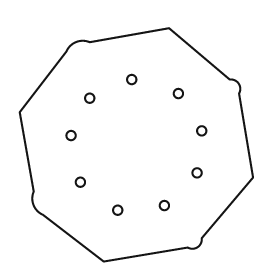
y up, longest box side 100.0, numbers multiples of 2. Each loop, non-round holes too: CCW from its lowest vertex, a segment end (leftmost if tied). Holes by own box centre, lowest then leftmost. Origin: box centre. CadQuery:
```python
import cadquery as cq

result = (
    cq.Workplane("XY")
    .moveTo(-14.0, -50.0)
    .lineTo(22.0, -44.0)
    .threePointArc((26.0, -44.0), (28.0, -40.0))
    .lineTo(50.0, -14.0)
    .lineTo(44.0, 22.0)
    .threePointArc((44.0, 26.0), (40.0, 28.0))
    .lineTo(14.0, 50.0)
    .lineTo(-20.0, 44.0)
    .threePointArc((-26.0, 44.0), (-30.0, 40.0))
    .lineTo(-50.0, 14.0)
    .lineTo(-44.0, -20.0)
    .threePointArc((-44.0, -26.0), (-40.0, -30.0))
    .close()
    .moveTo(-8.0, -28.0)
    .circle(2.0)
    .moveTo(12.0, -26.0)
    .circle(2.0)
    .moveTo(-24.0, -16.0)
    .circle(2.0)
    .moveTo(26.0, -12.0)
    .circle(2.0)
    .moveTo(-28.0, 4.0)
    .circle(2.0)
    .moveTo(28.0, 6.0)
    .circle(2.0)
    .moveTo(-20.0, 20.0)
    .circle(2.0)
    .moveTo(18.0, 22.0)
    .circle(2.0)
    .moveTo(-2.0, 28.0)
    .circle(2.0)
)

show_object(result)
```